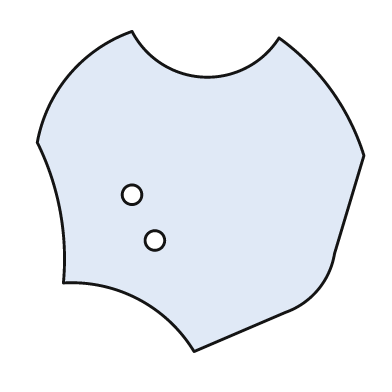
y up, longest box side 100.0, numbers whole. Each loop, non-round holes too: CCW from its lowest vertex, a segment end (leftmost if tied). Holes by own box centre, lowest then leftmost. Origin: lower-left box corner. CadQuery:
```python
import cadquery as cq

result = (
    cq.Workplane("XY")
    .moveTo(48.0, 0.0)
    .lineTo(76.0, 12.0)
    .threePointArc((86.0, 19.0), (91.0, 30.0))
    .lineTo(100.0, 60.0)
    .threePointArc((90.0, 80.0), (74.0, 96.0))
    .threePointArc((51.0, 84.0), (29.0, 98.0))
    .threePointArc((10.0, 85.0), (0.0, 64.0))
    .threePointArc((7.0, 43.0), (8.0, 21.0))
    .threePointArc((31.0, 16.0), (48.0, 0.0))
    .close()
    .moveTo(36.0, 34.0)
    .circle(3.0)
    .moveTo(29.0, 48.0)
    .circle(3.0)
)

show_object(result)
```